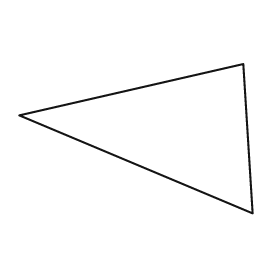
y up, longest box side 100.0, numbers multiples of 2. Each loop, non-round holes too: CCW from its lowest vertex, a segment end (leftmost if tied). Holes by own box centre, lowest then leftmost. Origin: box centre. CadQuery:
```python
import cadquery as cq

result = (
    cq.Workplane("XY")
    .moveTo(50.0, -32.0)
    .lineTo(46.0, 32.0)
    .lineTo(-50.0, 10.0)
    .close()
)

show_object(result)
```